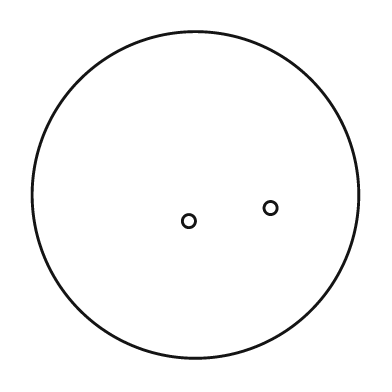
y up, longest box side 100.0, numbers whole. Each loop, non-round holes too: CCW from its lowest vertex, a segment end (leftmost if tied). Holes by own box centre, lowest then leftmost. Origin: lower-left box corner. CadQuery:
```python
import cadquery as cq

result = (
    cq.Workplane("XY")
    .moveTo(50.0, 50.0)
    .circle(50.0)
    .moveTo(48.0, 42.0)
    .circle(2.0)
    .moveTo(73.0, 46.0)
    .circle(2.0)
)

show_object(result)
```